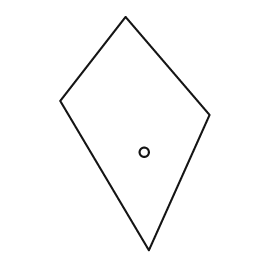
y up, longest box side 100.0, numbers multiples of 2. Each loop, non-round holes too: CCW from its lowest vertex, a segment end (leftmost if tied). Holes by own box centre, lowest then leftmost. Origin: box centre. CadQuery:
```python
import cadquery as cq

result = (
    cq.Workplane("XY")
    .moveTo(6.0, -50.0)
    .lineTo(32.0, 8.0)
    .lineTo(-4.0, 50.0)
    .lineTo(-32.0, 14.0)
    .close()
    .moveTo(4.0, -8.0)
    .circle(2.0)
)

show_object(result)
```